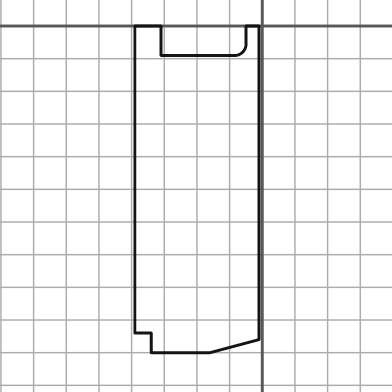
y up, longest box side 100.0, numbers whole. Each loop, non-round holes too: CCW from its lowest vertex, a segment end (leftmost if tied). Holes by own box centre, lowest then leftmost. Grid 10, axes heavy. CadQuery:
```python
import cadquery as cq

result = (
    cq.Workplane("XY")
    .moveTo(-34.0, -100.0)
    .lineTo(-16.0, -100.0)
    .lineTo(-1.0, -96.0)
    .lineTo(-1.0, 0.0)
    .lineTo(-5.0, 0.0)
    .lineTo(-5.0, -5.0)
    .threePointArc((-6.0, -8.0), (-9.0, -9.0))
    .lineTo(-31.0, -9.0)
    .lineTo(-31.0, 0.0)
    .lineTo(-39.0, 0.0)
    .lineTo(-39.0, -94.0)
    .lineTo(-34.0, -94.0)
    .close()
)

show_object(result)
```